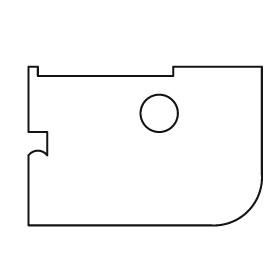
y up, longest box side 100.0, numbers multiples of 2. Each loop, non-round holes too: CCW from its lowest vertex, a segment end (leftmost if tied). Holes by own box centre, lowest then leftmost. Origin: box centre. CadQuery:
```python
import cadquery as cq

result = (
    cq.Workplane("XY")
    .moveTo(-50.0, -34.0)
    .lineTo(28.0, -34.0)
    .threePointArc((44.0, -28.0), (50.0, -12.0))
    .lineTo(50.0, 34.0)
    .lineTo(12.0, 34.0)
    .lineTo(12.0, 30.0)
    .lineTo(-46.0, 30.0)
    .lineTo(-46.0, 34.0)
    .lineTo(-50.0, 34.0)
    .lineTo(-50.0, 6.0)
    .lineTo(-42.0, 6.0)
    .lineTo(-42.0, -4.0)
    .threePointArc((-46.0, -2.0), (-50.0, -4.0))
    .close()
    .moveTo(6.0, 14.0)
    .circle(8.0)
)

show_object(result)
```